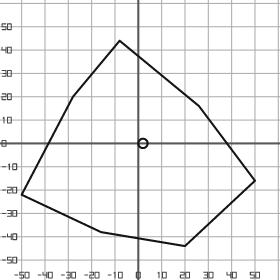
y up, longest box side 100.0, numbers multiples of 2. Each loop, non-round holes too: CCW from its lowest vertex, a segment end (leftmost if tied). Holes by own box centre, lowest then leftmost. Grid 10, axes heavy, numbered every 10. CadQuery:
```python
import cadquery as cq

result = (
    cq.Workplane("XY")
    .moveTo(20.0, -44.0)
    .lineTo(50.0, -16.0)
    .lineTo(26.0, 16.0)
    .lineTo(-8.0, 44.0)
    .lineTo(-28.0, 20.0)
    .lineTo(-50.0, -22.0)
    .lineTo(-16.0, -38.0)
    .close()
    .moveTo(2.0, 0.0)
    .circle(2.0)
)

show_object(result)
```